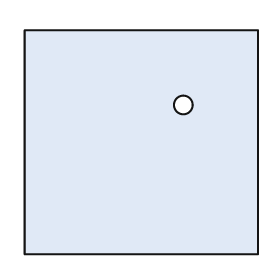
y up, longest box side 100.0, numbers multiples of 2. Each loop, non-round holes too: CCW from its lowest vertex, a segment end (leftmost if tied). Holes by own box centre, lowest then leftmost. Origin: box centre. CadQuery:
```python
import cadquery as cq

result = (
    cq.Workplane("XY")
    .moveTo(-50.0, -48.0)
    .lineTo(50.0, -48.0)
    .lineTo(50.0, 48.0)
    .lineTo(-50.0, 48.0)
    .close()
    .moveTo(18.0, 16.0)
    .circle(4.0)
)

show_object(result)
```